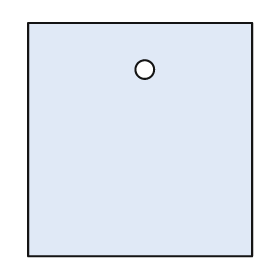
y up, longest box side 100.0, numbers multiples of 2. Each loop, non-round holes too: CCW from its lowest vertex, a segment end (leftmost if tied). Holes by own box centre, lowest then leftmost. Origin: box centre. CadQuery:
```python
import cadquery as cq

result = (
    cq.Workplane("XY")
    .moveTo(-48.0, -50.0)
    .lineTo(48.0, -50.0)
    .lineTo(48.0, 50.0)
    .lineTo(-48.0, 50.0)
    .close()
    .moveTo(2.0, 30.0)
    .circle(4.0)
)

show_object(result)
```